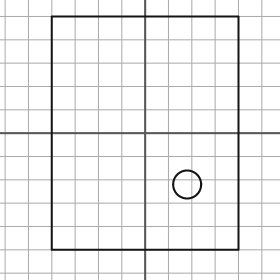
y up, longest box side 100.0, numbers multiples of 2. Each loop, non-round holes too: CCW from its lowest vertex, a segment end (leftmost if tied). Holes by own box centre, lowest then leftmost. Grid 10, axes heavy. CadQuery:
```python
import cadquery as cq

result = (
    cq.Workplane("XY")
    .moveTo(-40.0, -50.0)
    .lineTo(40.0, -50.0)
    .lineTo(40.0, 50.0)
    .lineTo(-40.0, 50.0)
    .close()
    .moveTo(18.0, -22.0)
    .circle(6.0)
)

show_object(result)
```